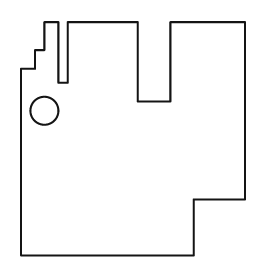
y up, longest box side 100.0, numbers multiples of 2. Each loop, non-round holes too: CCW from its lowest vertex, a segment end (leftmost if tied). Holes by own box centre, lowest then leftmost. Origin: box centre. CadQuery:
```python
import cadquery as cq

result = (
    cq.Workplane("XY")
    .moveTo(-48.0, -50.0)
    .lineTo(26.0, -50.0)
    .lineTo(26.0, -26.0)
    .lineTo(48.0, -26.0)
    .lineTo(48.0, 50.0)
    .lineTo(16.0, 50.0)
    .lineTo(16.0, 16.0)
    .lineTo(2.0, 16.0)
    .lineTo(2.0, 50.0)
    .lineTo(-28.0, 50.0)
    .lineTo(-28.0, 24.0)
    .lineTo(-32.0, 24.0)
    .lineTo(-32.0, 50.0)
    .lineTo(-38.0, 50.0)
    .lineTo(-38.0, 38.0)
    .lineTo(-42.0, 38.0)
    .lineTo(-42.0, 30.0)
    .lineTo(-48.0, 30.0)
    .close()
    .moveTo(-38.0, 12.0)
    .circle(6.0)
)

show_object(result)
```